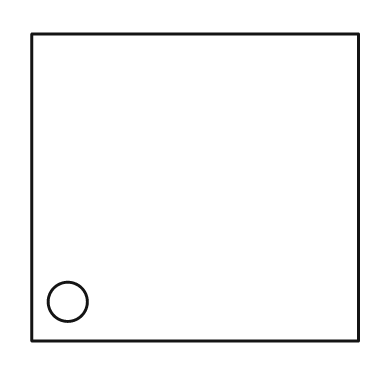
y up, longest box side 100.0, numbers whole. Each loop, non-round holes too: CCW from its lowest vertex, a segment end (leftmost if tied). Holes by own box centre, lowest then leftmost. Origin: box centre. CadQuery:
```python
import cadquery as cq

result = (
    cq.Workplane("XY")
    .moveTo(-50.0, -47.0)
    .lineTo(50.0, -47.0)
    .lineTo(50.0, 47.0)
    .lineTo(-50.0, 47.0)
    .close()
    .moveTo(-39.0, -35.0)
    .circle(6.0)
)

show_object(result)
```